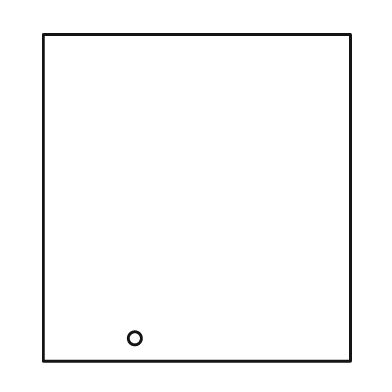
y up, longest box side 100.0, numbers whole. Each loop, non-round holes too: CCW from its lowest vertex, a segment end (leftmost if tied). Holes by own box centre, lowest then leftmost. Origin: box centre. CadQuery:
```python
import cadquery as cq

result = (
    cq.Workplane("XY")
    .moveTo(-47.0, -50.0)
    .lineTo(47.0, -50.0)
    .lineTo(47.0, 50.0)
    .lineTo(-47.0, 50.0)
    .close()
    .moveTo(-19.0, -43.0)
    .circle(2.0)
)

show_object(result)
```